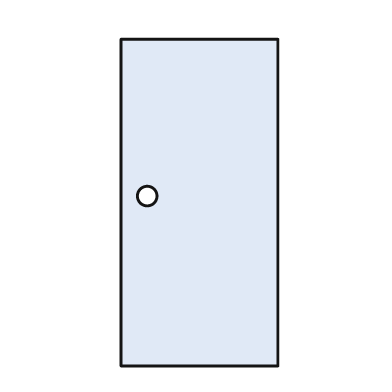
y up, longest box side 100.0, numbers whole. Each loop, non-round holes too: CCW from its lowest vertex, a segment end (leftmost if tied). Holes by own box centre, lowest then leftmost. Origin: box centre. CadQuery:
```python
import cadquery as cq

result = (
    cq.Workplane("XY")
    .moveTo(-24.0, -50.0)
    .lineTo(24.0, -50.0)
    .lineTo(24.0, 50.0)
    .lineTo(-24.0, 50.0)
    .close()
    .moveTo(-16.0, 2.0)
    .circle(3.0)
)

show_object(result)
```